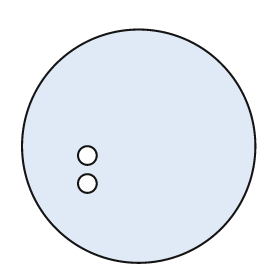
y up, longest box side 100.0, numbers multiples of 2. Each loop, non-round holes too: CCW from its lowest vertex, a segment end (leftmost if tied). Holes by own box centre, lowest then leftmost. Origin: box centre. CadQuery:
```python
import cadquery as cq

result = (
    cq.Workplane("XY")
    .moveTo(0.0, 0.0)
    .circle(50.0)
    .moveTo(-22.0, -16.0)
    .circle(4.0)
    .moveTo(-22.0, -4.0)
    .circle(4.0)
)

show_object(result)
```